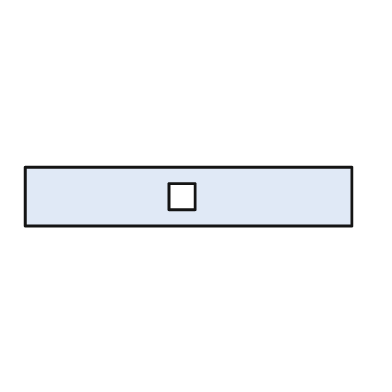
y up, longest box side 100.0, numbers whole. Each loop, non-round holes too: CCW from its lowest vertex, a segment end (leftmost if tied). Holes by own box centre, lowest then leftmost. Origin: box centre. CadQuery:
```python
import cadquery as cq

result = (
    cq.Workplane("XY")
    .moveTo(-50.0, -9.0)
    .lineTo(50.0, -9.0)
    .lineTo(50.0, 9.0)
    .lineTo(-50.0, 9.0)
    .close()
    .moveTo(-6.0, -4.0)
    .lineTo(2.0, -4.0)
    .lineTo(2.0, 4.0)
    .lineTo(-6.0, 4.0)
    .close()
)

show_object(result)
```